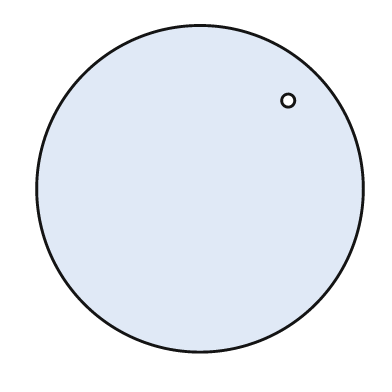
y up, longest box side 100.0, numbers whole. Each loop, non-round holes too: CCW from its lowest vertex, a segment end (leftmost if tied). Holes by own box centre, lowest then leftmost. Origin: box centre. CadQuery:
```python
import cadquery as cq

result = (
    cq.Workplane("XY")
    .moveTo(0.0, 0.0)
    .circle(50.0)
    .moveTo(27.0, 27.0)
    .circle(2.0)
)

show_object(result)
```